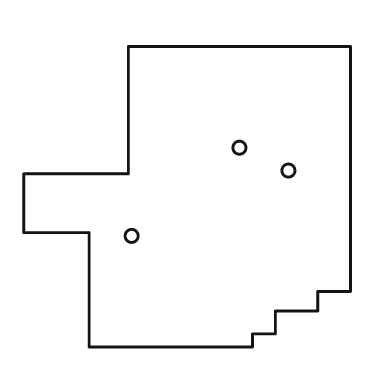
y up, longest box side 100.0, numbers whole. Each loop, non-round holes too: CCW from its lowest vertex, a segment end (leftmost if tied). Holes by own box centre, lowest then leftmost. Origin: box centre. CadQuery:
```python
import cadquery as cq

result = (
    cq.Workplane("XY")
    .moveTo(-30.0, -46.0)
    .lineTo(20.0, -46.0)
    .lineTo(20.0, -42.0)
    .lineTo(27.0, -42.0)
    .lineTo(27.0, -35.0)
    .lineTo(40.0, -35.0)
    .lineTo(40.0, -29.0)
    .lineTo(50.0, -29.0)
    .lineTo(50.0, 46.0)
    .lineTo(-18.0, 46.0)
    .lineTo(-18.0, 7.0)
    .lineTo(-50.0, 7.0)
    .lineTo(-50.0, -11.0)
    .lineTo(-30.0, -11.0)
    .close()
    .moveTo(-17.0, -12.0)
    .circle(2.0)
    .moveTo(31.0, 8.0)
    .circle(2.0)
    .moveTo(16.0, 15.0)
    .circle(2.0)
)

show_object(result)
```